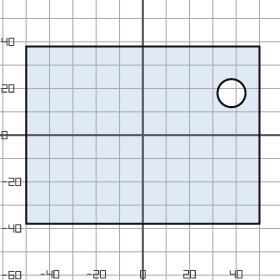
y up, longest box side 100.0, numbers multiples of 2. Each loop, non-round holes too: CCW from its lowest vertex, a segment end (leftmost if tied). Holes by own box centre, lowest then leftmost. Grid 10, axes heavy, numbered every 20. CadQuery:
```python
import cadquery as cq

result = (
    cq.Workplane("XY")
    .moveTo(-50.0, -38.0)
    .lineTo(50.0, -38.0)
    .lineTo(50.0, 38.0)
    .lineTo(-50.0, 38.0)
    .close()
    .moveTo(38.0, 18.0)
    .circle(6.0)
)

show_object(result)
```